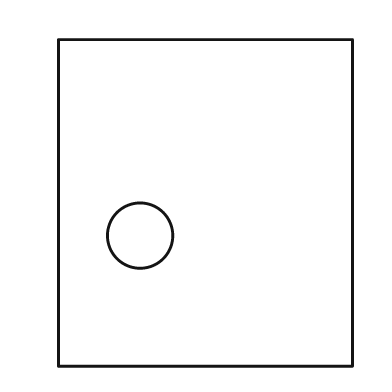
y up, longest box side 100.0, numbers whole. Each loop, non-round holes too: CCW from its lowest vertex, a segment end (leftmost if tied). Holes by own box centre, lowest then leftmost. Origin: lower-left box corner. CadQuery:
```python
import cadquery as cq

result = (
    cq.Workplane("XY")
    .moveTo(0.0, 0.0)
    .lineTo(90.0, 0.0)
    .lineTo(90.0, 100.0)
    .lineTo(0.0, 100.0)
    .close()
    .moveTo(25.0, 40.0)
    .circle(10.0)
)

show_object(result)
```